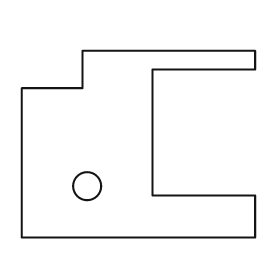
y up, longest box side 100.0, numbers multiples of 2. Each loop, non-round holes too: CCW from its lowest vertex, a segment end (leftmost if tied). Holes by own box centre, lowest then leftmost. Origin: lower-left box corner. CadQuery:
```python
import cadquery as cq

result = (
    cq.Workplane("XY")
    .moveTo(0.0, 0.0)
    .lineTo(100.0, 0.0)
    .lineTo(100.0, 18.0)
    .lineTo(56.0, 18.0)
    .lineTo(56.0, 72.0)
    .lineTo(100.0, 72.0)
    .lineTo(100.0, 80.0)
    .lineTo(26.0, 80.0)
    .lineTo(26.0, 64.0)
    .lineTo(0.0, 64.0)
    .close()
    .moveTo(28.0, 22.0)
    .circle(6.0)
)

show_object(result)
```